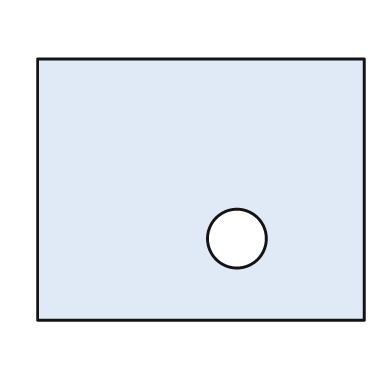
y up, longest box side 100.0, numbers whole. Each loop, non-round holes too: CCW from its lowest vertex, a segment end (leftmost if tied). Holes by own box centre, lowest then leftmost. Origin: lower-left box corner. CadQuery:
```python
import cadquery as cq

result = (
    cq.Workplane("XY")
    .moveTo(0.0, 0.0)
    .lineTo(100.0, 0.0)
    .lineTo(100.0, 80.0)
    .lineTo(0.0, 80.0)
    .close()
    .moveTo(61.0, 25.0)
    .circle(9.0)
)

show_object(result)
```